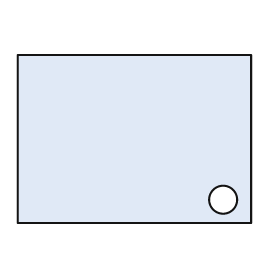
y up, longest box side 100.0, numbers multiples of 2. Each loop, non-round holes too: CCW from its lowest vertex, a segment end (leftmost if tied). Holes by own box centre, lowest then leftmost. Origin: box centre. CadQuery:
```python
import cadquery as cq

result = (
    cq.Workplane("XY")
    .moveTo(-50.0, -36.0)
    .lineTo(50.0, -36.0)
    .lineTo(50.0, 36.0)
    .lineTo(-50.0, 36.0)
    .close()
    .moveTo(38.0, -26.0)
    .circle(6.0)
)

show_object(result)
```